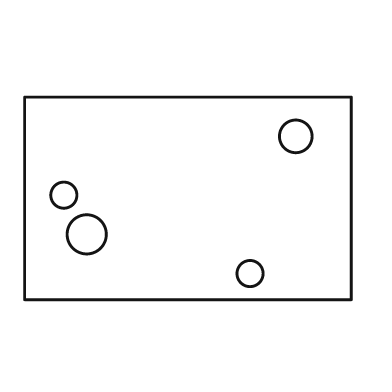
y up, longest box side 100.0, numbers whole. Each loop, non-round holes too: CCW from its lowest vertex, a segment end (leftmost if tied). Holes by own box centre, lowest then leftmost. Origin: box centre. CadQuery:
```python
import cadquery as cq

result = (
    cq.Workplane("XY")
    .moveTo(-50.0, -31.0)
    .lineTo(50.0, -31.0)
    .lineTo(50.0, 31.0)
    .lineTo(-50.0, 31.0)
    .close()
    .moveTo(19.0, -23.0)
    .circle(4.0)
    .moveTo(-31.0, -11.0)
    .circle(6.0)
    .moveTo(-38.0, 1.0)
    .circle(4.0)
    .moveTo(33.0, 19.0)
    .circle(5.0)
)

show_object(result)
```